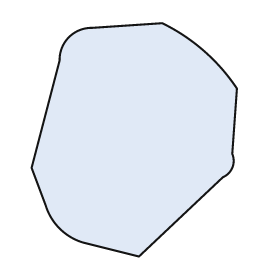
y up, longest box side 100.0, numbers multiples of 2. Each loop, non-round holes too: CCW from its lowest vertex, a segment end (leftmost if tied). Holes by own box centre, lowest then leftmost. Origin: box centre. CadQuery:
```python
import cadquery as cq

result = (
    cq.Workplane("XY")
    .moveTo(2.0, -50.0)
    .lineTo(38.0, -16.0)
    .threePointArc((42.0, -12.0), (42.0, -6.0))
    .lineTo(44.0, 22.0)
    .threePointArc((30.0, 38.0), (12.0, 50.0))
    .lineTo(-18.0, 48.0)
    .threePointArc((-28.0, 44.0), (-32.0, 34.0))
    .lineTo(-44.0, -12.0)
    .lineTo(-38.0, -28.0)
    .threePointArc((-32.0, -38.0), (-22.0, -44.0))
    .close()
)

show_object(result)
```